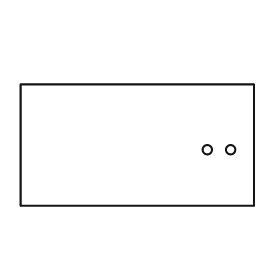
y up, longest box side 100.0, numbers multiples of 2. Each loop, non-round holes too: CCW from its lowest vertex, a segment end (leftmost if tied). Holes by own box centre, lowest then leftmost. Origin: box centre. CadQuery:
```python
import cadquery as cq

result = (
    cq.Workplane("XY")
    .moveTo(-50.0, -26.0)
    .lineTo(50.0, -26.0)
    .lineTo(50.0, 26.0)
    .lineTo(-50.0, 26.0)
    .close()
    .moveTo(30.0, -2.0)
    .circle(2.0)
    .moveTo(40.0, -2.0)
    .circle(2.0)
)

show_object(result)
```